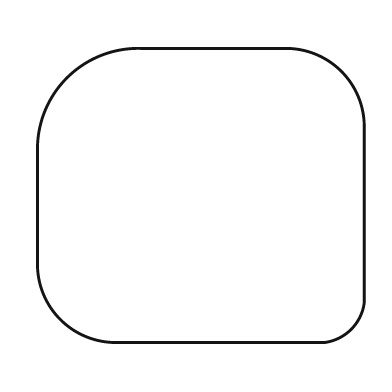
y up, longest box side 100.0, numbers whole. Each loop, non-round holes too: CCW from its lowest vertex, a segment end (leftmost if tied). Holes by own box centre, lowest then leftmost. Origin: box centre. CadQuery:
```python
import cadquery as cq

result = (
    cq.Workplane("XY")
    .moveTo(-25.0, -45.0)
    .lineTo(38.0, -45.0)
    .threePointArc((46.0, -41.0), (50.0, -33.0))
    .lineTo(50.0, 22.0)
    .threePointArc((43.0, 38.0), (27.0, 45.0))
    .lineTo(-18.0, 45.0)
    .threePointArc((-41.0, 36.0), (-50.0, 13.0))
    .lineTo(-50.0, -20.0)
    .threePointArc((-43.0, -38.0), (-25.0, -45.0))
    .close()
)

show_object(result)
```